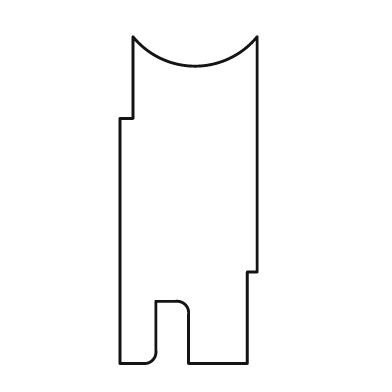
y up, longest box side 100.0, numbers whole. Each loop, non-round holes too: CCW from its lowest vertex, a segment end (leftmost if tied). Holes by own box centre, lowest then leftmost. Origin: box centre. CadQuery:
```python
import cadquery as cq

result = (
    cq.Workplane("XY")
    .moveTo(-21.0, -50.0)
    .lineTo(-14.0, -50.0)
    .threePointArc((-11.0, -49.0), (-10.0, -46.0))
    .lineTo(-10.0, -31.0)
    .lineTo(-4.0, -31.0)
    .threePointArc((-1.0, -32.0), (0.0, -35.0))
    .lineTo(0.0, -50.0)
    .lineTo(18.0, -50.0)
    .lineTo(18.0, -22.0)
    .lineTo(21.0, -22.0)
    .lineTo(21.0, 50.0)
    .threePointArc((2.0, 41.0), (-17.0, 50.0))
    .lineTo(-17.0, 25.0)
    .lineTo(-21.0, 25.0)
    .close()
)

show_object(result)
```